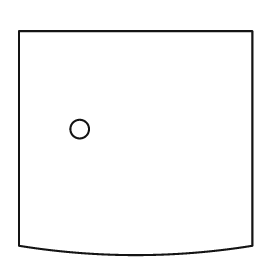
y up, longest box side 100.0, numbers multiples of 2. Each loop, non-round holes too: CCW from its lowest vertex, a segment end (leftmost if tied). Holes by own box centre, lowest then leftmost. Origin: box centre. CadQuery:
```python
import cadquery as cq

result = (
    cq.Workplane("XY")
    .moveTo(-50.0, -44.0)
    .threePointArc((0.0, -48.0), (50.0, -44.0))
    .lineTo(50.0, 48.0)
    .lineTo(-50.0, 48.0)
    .close()
    .moveTo(-24.0, 6.0)
    .circle(4.0)
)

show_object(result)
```